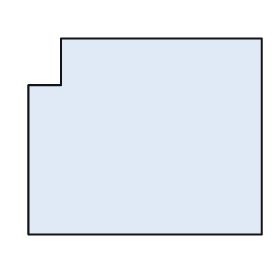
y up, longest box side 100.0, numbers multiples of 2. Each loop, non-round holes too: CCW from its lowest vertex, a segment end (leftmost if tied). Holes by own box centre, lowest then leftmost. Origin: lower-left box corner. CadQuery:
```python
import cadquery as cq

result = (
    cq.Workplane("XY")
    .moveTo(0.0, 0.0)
    .lineTo(100.0, 0.0)
    .lineTo(100.0, 84.0)
    .lineTo(14.0, 84.0)
    .lineTo(14.0, 64.0)
    .lineTo(0.0, 64.0)
    .close()
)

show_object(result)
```